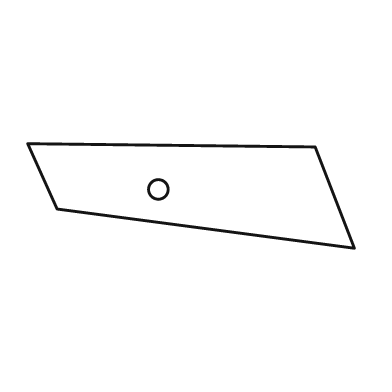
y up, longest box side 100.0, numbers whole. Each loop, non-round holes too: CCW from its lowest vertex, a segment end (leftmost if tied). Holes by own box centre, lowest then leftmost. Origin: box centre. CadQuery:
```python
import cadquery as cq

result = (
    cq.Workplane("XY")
    .moveTo(50.0, -16.0)
    .lineTo(38.0, 15.0)
    .lineTo(-50.0, 16.0)
    .lineTo(-41.0, -4.0)
    .close()
    .moveTo(-10.0, 2.0)
    .circle(3.0)
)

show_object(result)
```